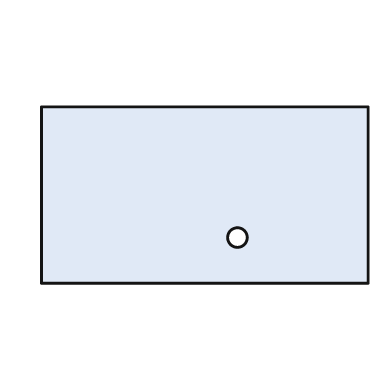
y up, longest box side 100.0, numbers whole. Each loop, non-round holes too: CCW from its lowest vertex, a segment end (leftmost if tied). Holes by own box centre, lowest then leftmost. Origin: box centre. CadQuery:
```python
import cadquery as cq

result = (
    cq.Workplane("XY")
    .moveTo(-50.0, -27.0)
    .lineTo(50.0, -27.0)
    .lineTo(50.0, 27.0)
    .lineTo(-50.0, 27.0)
    .close()
    .moveTo(10.0, -13.0)
    .circle(3.0)
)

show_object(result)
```